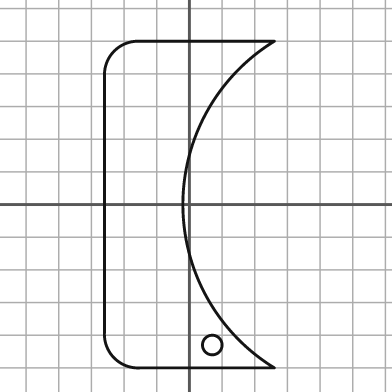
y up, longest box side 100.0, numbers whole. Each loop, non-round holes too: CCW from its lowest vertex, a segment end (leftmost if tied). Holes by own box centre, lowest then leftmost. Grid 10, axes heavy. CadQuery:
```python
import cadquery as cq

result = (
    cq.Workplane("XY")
    .moveTo(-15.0, -50.0)
    .lineTo(26.0, -50.0)
    .threePointArc((-2.0, 0.0), (26.0, 50.0))
    .lineTo(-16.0, 50.0)
    .threePointArc((-23.0, 47.0), (-26.0, 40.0))
    .lineTo(-26.0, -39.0)
    .threePointArc((-23.0, -47.0), (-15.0, -50.0))
    .close()
    .moveTo(7.0, -43.0)
    .circle(3.0)
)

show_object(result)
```